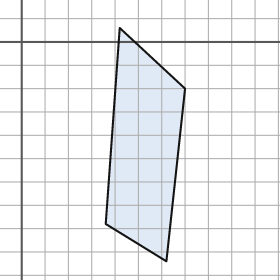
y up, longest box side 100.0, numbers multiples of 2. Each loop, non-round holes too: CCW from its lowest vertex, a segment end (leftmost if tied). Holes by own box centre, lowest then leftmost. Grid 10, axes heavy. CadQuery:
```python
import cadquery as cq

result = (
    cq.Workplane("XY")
    .moveTo(62.0, -94.0)
    .lineTo(70.0, -20.0)
    .lineTo(42.0, 6.0)
    .lineTo(36.0, -78.0)
    .close()
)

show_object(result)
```